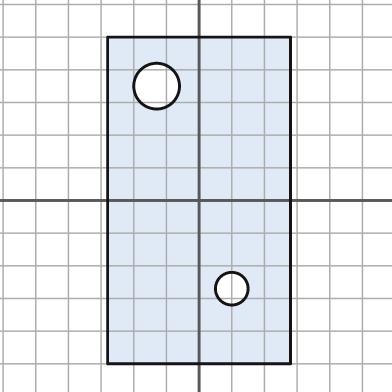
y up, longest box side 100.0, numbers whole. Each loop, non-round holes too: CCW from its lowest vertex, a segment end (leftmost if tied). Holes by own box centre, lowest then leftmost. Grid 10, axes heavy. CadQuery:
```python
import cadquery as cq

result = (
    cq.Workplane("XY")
    .moveTo(-28.0, -50.0)
    .lineTo(28.0, -50.0)
    .lineTo(28.0, 50.0)
    .lineTo(-28.0, 50.0)
    .close()
    .moveTo(10.0, -27.0)
    .circle(5.0)
    .moveTo(-13.0, 35.0)
    .circle(7.0)
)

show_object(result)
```